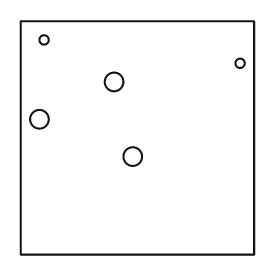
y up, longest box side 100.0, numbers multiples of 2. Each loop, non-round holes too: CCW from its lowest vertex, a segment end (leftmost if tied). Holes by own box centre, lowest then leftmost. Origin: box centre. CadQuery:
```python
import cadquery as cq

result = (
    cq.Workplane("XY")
    .moveTo(-50.0, -50.0)
    .lineTo(50.0, -50.0)
    .lineTo(50.0, 50.0)
    .lineTo(-50.0, 50.0)
    .close()
    .moveTo(-2.0, -8.0)
    .circle(4.0)
    .moveTo(-42.0, 8.0)
    .circle(4.0)
    .moveTo(-10.0, 24.0)
    .circle(4.0)
    .moveTo(44.0, 32.0)
    .circle(2.0)
    .moveTo(-40.0, 42.0)
    .circle(2.0)
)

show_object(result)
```